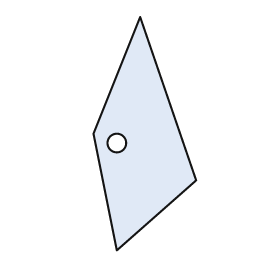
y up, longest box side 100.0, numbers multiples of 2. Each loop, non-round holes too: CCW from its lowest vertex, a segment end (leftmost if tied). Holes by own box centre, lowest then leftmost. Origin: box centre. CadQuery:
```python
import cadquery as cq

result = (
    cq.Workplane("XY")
    .moveTo(-12.0, -50.0)
    .lineTo(22.0, -20.0)
    .lineTo(-2.0, 50.0)
    .lineTo(-22.0, 0.0)
    .close()
    .moveTo(-12.0, -4.0)
    .circle(4.0)
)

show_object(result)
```